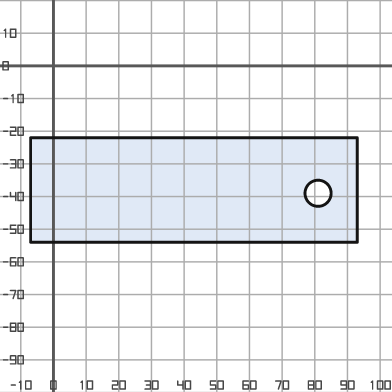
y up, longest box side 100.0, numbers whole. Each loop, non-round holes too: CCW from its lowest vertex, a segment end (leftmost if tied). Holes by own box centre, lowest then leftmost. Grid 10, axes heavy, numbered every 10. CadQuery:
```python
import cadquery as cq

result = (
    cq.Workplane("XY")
    .moveTo(-7.0, -54.0)
    .lineTo(93.0, -54.0)
    .lineTo(93.0, -22.0)
    .lineTo(-7.0, -22.0)
    .close()
    .moveTo(81.0, -39.0)
    .circle(4.0)
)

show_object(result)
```